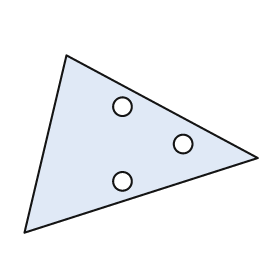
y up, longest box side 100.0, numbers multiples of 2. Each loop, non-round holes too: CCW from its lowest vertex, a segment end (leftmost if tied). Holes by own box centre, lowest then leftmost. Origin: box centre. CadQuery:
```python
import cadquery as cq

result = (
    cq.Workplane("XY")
    .moveTo(-50.0, -38.0)
    .lineTo(50.0, -6.0)
    .lineTo(-32.0, 38.0)
    .close()
    .moveTo(-8.0, -16.0)
    .circle(4.0)
    .moveTo(18.0, 0.0)
    .circle(4.0)
    .moveTo(-8.0, 16.0)
    .circle(4.0)
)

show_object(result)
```